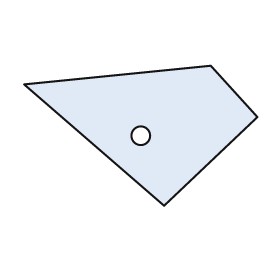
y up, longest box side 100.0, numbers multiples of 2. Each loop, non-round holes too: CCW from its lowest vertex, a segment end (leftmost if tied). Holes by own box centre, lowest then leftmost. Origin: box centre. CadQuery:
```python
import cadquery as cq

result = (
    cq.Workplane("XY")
    .moveTo(10.0, -30.0)
    .lineTo(50.0, 8.0)
    .lineTo(30.0, 30.0)
    .lineTo(-50.0, 22.0)
    .close()
    .moveTo(0.0, 0.0)
    .circle(4.0)
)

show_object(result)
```